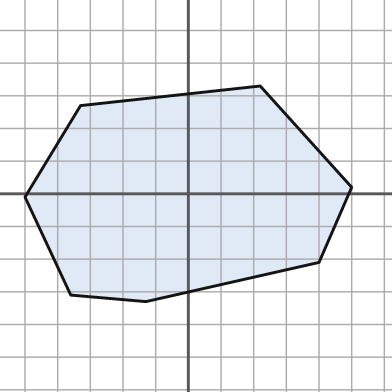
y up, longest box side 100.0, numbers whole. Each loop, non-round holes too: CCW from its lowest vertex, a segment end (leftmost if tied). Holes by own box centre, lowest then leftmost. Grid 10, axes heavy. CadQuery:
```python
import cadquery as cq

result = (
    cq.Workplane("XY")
    .moveTo(-13.0, -33.0)
    .lineTo(40.0, -21.0)
    .lineTo(50.0, 2.0)
    .lineTo(22.0, 33.0)
    .lineTo(-33.0, 27.0)
    .lineTo(-50.0, -1.0)
    .lineTo(-36.0, -31.0)
    .close()
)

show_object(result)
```